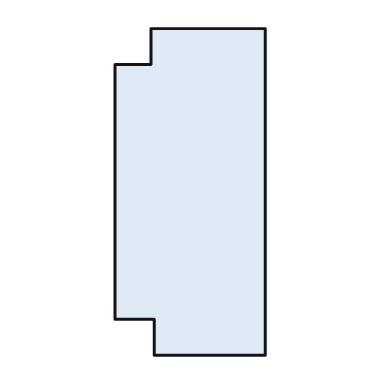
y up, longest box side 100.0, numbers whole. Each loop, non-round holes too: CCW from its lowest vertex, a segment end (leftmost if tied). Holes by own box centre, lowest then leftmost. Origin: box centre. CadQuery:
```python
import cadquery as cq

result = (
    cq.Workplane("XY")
    .moveTo(-11.0, -50.0)
    .lineTo(23.0, -50.0)
    .lineTo(23.0, 50.0)
    .lineTo(-12.0, 50.0)
    .lineTo(-12.0, 39.0)
    .lineTo(-23.0, 39.0)
    .lineTo(-23.0, -39.0)
    .lineTo(-11.0, -39.0)
    .close()
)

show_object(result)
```